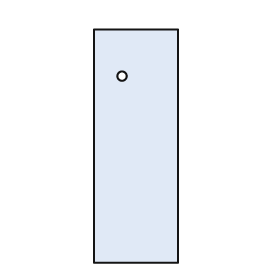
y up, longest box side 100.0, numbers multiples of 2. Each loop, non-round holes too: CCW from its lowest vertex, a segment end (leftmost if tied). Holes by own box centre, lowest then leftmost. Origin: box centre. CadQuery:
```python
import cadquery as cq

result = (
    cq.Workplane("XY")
    .moveTo(-18.0, -50.0)
    .lineTo(18.0, -50.0)
    .lineTo(18.0, 50.0)
    .lineTo(-18.0, 50.0)
    .close()
    .moveTo(-6.0, 30.0)
    .circle(2.0)
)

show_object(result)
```